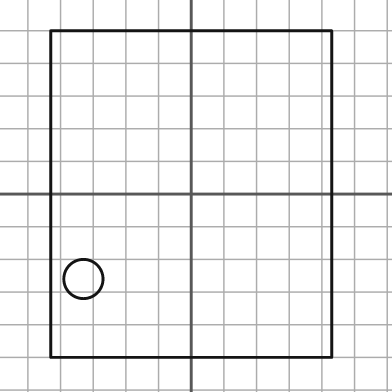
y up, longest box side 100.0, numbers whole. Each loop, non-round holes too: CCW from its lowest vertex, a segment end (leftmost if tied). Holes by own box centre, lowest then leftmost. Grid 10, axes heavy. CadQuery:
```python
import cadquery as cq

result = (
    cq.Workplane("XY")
    .moveTo(-43.0, -50.0)
    .lineTo(43.0, -50.0)
    .lineTo(43.0, 50.0)
    .lineTo(-43.0, 50.0)
    .close()
    .moveTo(-33.0, -26.0)
    .circle(6.0)
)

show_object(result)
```